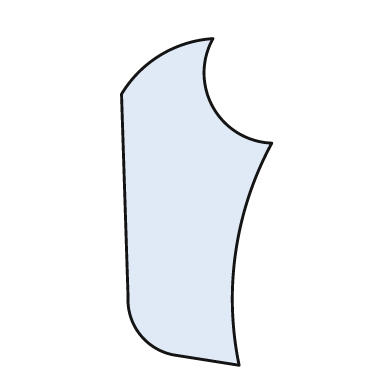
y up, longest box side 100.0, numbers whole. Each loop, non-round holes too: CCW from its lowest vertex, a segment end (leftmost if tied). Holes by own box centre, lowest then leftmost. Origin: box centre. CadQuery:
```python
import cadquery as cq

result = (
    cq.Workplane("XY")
    .moveTo(13.0, -50.0)
    .threePointArc((12.0, -15.0), (23.0, 18.0))
    .threePointArc((5.0, 29.0), (5.0, 50.0))
    .threePointArc((-11.0, 45.0), (-23.0, 33.0))
    .lineTo(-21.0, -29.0)
    .threePointArc((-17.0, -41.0), (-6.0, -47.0))
    .close()
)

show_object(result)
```